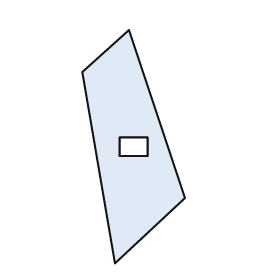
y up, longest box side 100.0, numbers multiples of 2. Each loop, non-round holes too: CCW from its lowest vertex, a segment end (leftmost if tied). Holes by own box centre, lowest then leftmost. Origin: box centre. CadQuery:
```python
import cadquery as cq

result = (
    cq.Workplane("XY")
    .moveTo(-8.0, -50.0)
    .lineTo(22.0, -22.0)
    .lineTo(-2.0, 50.0)
    .lineTo(-22.0, 32.0)
    .close()
    .moveTo(-6.0, -4.0)
    .lineTo(6.0, -4.0)
    .lineTo(6.0, 4.0)
    .lineTo(-6.0, 4.0)
    .close()
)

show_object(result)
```